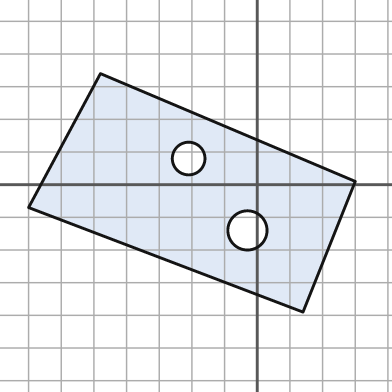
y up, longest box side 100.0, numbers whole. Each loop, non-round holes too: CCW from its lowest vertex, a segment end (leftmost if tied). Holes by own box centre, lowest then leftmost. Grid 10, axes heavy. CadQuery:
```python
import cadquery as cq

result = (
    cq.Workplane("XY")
    .moveTo(14.0, -39.0)
    .lineTo(30.0, 1.0)
    .lineTo(-48.0, 34.0)
    .lineTo(-70.0, -7.0)
    .close()
    .moveTo(-3.0, -14.0)
    .circle(6.0)
    .moveTo(-21.0, 8.0)
    .circle(5.0)
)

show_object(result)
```